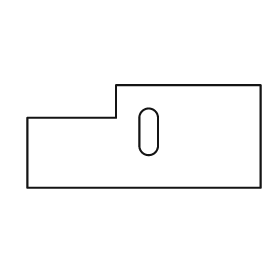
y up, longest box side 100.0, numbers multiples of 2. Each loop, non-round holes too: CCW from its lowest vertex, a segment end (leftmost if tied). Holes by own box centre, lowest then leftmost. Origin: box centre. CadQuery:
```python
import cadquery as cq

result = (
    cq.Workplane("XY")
    .moveTo(-50.0, -22.0)
    .lineTo(50.0, -22.0)
    .lineTo(50.0, 22.0)
    .lineTo(-12.0, 22.0)
    .lineTo(-12.0, 8.0)
    .lineTo(-50.0, 8.0)
    .close()
    .moveTo(-2.0, -4.0)
    .threePointArc((2.0, -8.0), (6.0, -4.0))
    .lineTo(6.0, 8.0)
    .threePointArc((2.0, 12.0), (-2.0, 8.0))
    .close()
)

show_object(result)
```